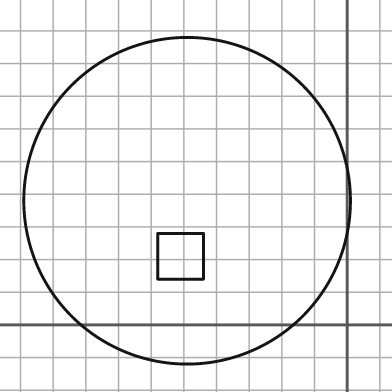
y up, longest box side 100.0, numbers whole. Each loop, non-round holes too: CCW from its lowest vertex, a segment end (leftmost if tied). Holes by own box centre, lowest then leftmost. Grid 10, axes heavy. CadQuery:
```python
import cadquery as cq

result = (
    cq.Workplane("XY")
    .moveTo(-49.0, 38.0)
    .circle(50.0)
    .moveTo(-58.0, 14.0)
    .lineTo(-44.0, 14.0)
    .lineTo(-44.0, 28.0)
    .lineTo(-58.0, 28.0)
    .close()
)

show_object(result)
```